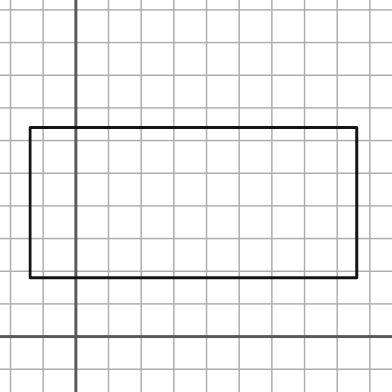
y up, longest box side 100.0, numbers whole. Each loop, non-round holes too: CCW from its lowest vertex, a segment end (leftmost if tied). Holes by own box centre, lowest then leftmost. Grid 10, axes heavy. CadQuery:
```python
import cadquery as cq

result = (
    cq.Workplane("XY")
    .moveTo(-14.0, 18.0)
    .lineTo(86.0, 18.0)
    .lineTo(86.0, 64.0)
    .lineTo(-14.0, 64.0)
    .close()
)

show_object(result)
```